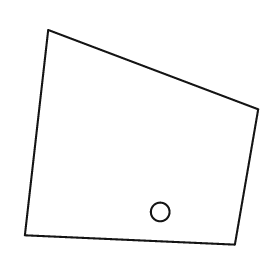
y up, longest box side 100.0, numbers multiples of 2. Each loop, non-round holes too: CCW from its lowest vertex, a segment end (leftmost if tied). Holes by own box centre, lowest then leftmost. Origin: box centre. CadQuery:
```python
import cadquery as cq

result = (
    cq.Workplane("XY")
    .moveTo(40.0, -46.0)
    .lineTo(50.0, 12.0)
    .lineTo(-40.0, 46.0)
    .lineTo(-50.0, -42.0)
    .close()
    .moveTo(8.0, -32.0)
    .circle(4.0)
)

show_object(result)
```